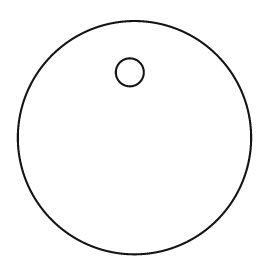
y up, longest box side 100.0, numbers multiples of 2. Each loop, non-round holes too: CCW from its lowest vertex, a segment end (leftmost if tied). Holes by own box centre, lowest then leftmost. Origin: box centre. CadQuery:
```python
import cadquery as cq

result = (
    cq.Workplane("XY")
    .moveTo(0.0, 0.0)
    .circle(50.0)
    .moveTo(-2.0, 28.0)
    .circle(6.0)
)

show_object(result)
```